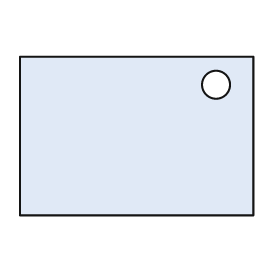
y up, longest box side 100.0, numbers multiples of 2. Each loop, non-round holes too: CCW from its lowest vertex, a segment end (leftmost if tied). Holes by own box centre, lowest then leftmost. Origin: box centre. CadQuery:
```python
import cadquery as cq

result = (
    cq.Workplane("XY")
    .moveTo(-50.0, -34.0)
    .lineTo(50.0, -34.0)
    .lineTo(50.0, 34.0)
    .lineTo(-50.0, 34.0)
    .close()
    .moveTo(34.0, 22.0)
    .circle(6.0)
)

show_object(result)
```